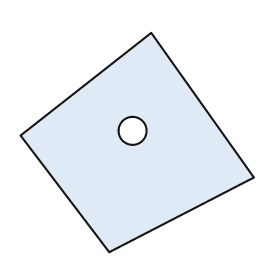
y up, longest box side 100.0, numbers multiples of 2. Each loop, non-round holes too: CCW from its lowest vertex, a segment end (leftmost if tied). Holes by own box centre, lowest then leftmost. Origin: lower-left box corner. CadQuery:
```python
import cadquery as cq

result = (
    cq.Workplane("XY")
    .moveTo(38.0, 0.0)
    .lineTo(100.0, 32.0)
    .lineTo(56.0, 94.0)
    .lineTo(0.0, 50.0)
    .close()
    .moveTo(48.0, 52.0)
    .circle(6.0)
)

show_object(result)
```